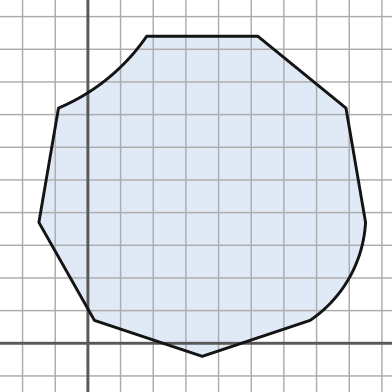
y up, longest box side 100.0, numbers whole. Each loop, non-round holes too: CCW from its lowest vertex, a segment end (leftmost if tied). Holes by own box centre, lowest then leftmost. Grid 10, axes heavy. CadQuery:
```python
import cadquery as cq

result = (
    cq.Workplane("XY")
    .moveTo(35.0, -4.0)
    .lineTo(68.0, 7.0)
    .threePointArc((80.0, 20.0), (85.0, 37.0))
    .lineTo(79.0, 72.0)
    .lineTo(52.0, 94.0)
    .lineTo(18.0, 94.0)
    .threePointArc((6.0, 81.0), (-9.0, 72.0))
    .lineTo(-15.0, 37.0)
    .lineTo(2.0, 7.0)
    .close()
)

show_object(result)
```